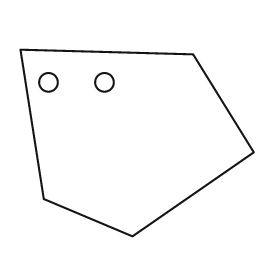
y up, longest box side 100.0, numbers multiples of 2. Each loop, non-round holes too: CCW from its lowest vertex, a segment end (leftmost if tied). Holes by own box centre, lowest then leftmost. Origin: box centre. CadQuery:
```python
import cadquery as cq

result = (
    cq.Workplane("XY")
    .moveTo(-2.0, -40.0)
    .lineTo(50.0, -4.0)
    .lineTo(24.0, 38.0)
    .lineTo(-50.0, 40.0)
    .lineTo(-40.0, -24.0)
    .close()
    .moveTo(-38.0, 26.0)
    .circle(4.0)
    .moveTo(-14.0, 26.0)
    .circle(4.0)
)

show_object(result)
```